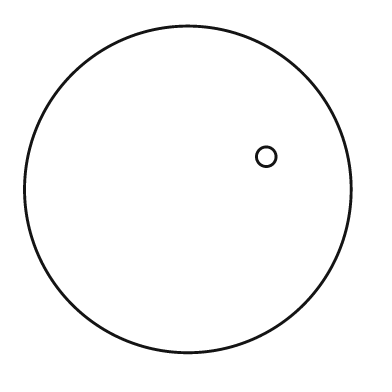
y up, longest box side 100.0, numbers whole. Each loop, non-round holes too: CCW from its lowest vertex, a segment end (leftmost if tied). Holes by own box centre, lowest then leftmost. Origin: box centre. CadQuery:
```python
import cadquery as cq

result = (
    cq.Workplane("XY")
    .moveTo(0.0, 0.0)
    .circle(50.0)
    .moveTo(24.0, 10.0)
    .circle(3.0)
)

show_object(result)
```